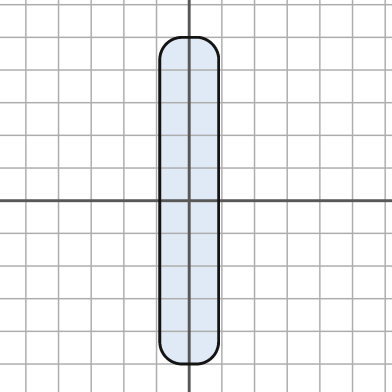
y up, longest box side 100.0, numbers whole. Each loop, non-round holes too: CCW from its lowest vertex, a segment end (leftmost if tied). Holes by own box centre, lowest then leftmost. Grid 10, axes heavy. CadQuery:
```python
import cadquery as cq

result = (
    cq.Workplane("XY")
    .moveTo(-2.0, -50.0)
    .lineTo(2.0, -50.0)
    .threePointArc((7.0, -48.0), (9.0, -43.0))
    .lineTo(9.0, 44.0)
    .threePointArc((7.0, 48.0), (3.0, 50.0))
    .lineTo(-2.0, 50.0)
    .threePointArc((-7.0, 48.0), (-9.0, 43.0))
    .lineTo(-9.0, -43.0)
    .threePointArc((-7.0, -48.0), (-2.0, -50.0))
    .close()
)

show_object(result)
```